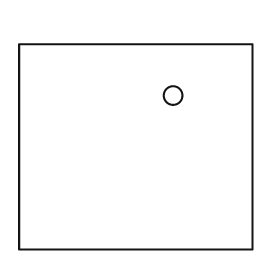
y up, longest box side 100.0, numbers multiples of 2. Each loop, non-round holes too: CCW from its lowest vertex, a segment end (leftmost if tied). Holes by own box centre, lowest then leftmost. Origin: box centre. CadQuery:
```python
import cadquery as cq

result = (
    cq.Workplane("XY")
    .moveTo(-50.0, -44.0)
    .lineTo(50.0, -44.0)
    .lineTo(50.0, 44.0)
    .lineTo(-50.0, 44.0)
    .close()
    .moveTo(16.0, 22.0)
    .circle(4.0)
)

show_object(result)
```